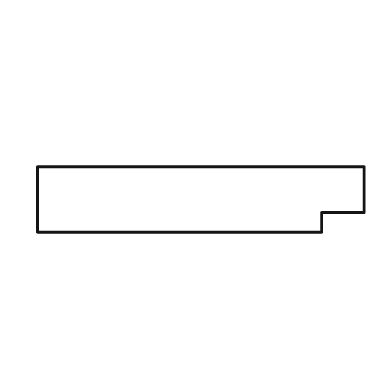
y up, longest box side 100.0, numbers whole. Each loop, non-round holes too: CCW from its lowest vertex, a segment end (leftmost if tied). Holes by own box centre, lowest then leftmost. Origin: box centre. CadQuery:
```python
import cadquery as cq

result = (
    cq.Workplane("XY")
    .moveTo(-50.0, -10.0)
    .lineTo(37.0, -10.0)
    .lineTo(37.0, -4.0)
    .lineTo(50.0, -4.0)
    .lineTo(50.0, 10.0)
    .lineTo(-50.0, 10.0)
    .close()
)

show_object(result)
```